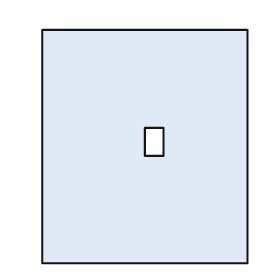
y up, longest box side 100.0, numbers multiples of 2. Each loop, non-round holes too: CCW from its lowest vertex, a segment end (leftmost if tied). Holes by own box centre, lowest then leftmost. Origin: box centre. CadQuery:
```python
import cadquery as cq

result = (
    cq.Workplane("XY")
    .moveTo(-44.0, -50.0)
    .lineTo(44.0, -50.0)
    .lineTo(44.0, 50.0)
    .lineTo(-44.0, 50.0)
    .close()
    .moveTo(0.0, -4.0)
    .lineTo(8.0, -4.0)
    .lineTo(8.0, 8.0)
    .lineTo(0.0, 8.0)
    .close()
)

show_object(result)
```